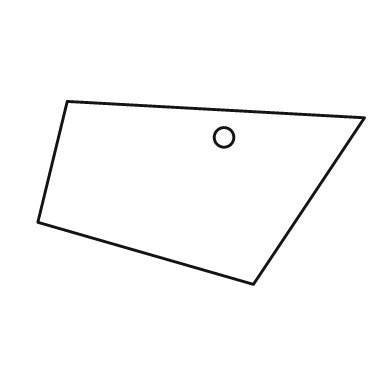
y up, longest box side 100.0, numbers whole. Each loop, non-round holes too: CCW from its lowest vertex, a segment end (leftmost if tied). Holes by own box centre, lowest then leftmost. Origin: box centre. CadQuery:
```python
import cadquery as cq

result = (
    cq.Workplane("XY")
    .moveTo(16.0, -28.0)
    .lineTo(50.0, 23.0)
    .lineTo(-41.0, 28.0)
    .lineTo(-50.0, -9.0)
    .close()
    .moveTo(7.0, 17.0)
    .circle(3.0)
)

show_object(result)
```